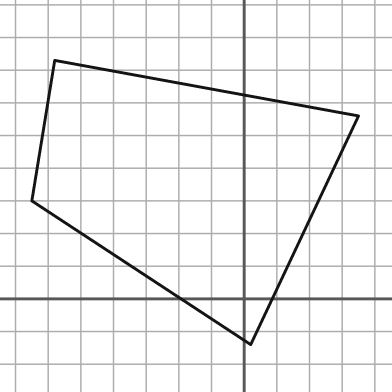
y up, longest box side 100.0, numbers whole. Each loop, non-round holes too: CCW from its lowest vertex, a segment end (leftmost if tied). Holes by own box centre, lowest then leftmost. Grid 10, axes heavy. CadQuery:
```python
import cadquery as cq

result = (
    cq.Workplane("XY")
    .moveTo(2.0, -14.0)
    .lineTo(35.0, 56.0)
    .lineTo(-58.0, 73.0)
    .lineTo(-65.0, 30.0)
    .close()
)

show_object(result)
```